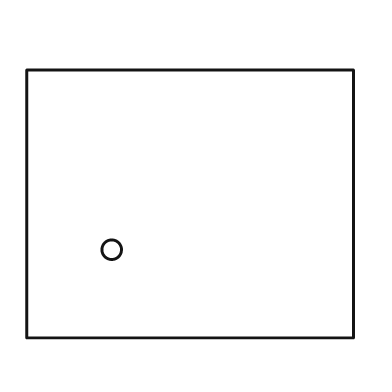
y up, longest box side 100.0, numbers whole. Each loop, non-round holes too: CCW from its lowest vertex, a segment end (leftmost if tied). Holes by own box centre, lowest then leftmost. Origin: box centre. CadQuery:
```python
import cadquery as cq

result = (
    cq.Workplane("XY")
    .moveTo(-50.0, -41.0)
    .lineTo(50.0, -41.0)
    .lineTo(50.0, 41.0)
    .lineTo(-50.0, 41.0)
    .close()
    .moveTo(-24.0, -14.0)
    .circle(3.0)
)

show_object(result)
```